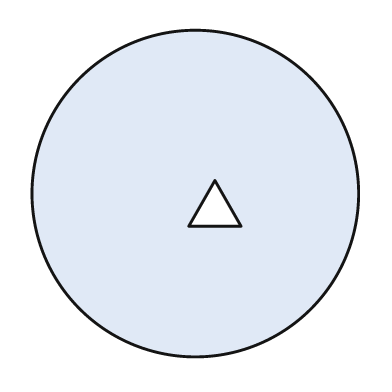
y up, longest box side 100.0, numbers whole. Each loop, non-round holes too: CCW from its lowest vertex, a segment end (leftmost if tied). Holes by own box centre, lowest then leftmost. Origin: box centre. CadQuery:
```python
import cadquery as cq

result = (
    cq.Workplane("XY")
    .moveTo(0.0, 0.0)
    .circle(50.0)
    .moveTo(-2.0, -10.0)
    .lineTo(14.0, -10.0)
    .lineTo(6.0, 4.0)
    .close()
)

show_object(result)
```